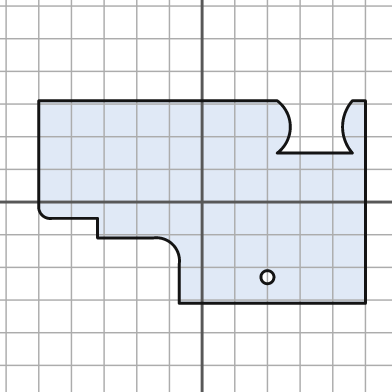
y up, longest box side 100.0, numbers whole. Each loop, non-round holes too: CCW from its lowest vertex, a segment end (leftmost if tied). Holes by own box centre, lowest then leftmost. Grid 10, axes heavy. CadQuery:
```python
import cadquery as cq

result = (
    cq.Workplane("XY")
    .moveTo(-7.0, -31.0)
    .lineTo(50.0, -31.0)
    .lineTo(50.0, 31.0)
    .lineTo(46.0, 31.0)
    .threePointArc((43.0, 23.0), (46.0, 15.0))
    .lineTo(23.0, 15.0)
    .threePointArc((27.0, 23.0), (23.0, 31.0))
    .lineTo(-50.0, 31.0)
    .lineTo(-50.0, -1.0)
    .threePointArc((-49.0, -4.0), (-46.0, -5.0))
    .lineTo(-32.0, -5.0)
    .lineTo(-32.0, -11.0)
    .lineTo(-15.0, -11.0)
    .threePointArc((-9.0, -13.0), (-7.0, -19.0))
    .close()
    .moveTo(20.0, -23.0)
    .circle(2.0)
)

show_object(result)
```